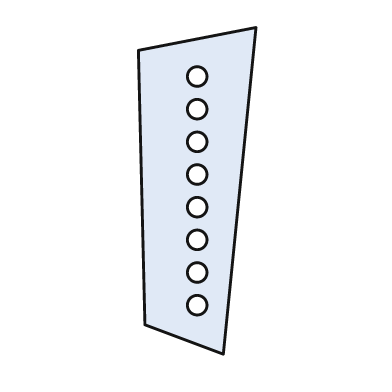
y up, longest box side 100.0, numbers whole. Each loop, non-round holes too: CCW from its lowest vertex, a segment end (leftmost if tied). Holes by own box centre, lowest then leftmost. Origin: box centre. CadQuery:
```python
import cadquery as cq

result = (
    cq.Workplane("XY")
    .moveTo(8.0, -50.0)
    .lineTo(18.0, 50.0)
    .lineTo(-18.0, 43.0)
    .lineTo(-16.0, -41.0)
    .close()
    .moveTo(0.0, -35.0)
    .circle(3.0)
    .moveTo(0.0, -25.0)
    .circle(3.0)
    .moveTo(0.0, -15.0)
    .circle(3.0)
    .moveTo(0.0, -5.0)
    .circle(3.0)
    .moveTo(0.0, 5.0)
    .circle(3.0)
    .moveTo(0.0, 15.0)
    .circle(3.0)
    .moveTo(0.0, 25.0)
    .circle(3.0)
    .moveTo(0.0, 35.0)
    .circle(3.0)
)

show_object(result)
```